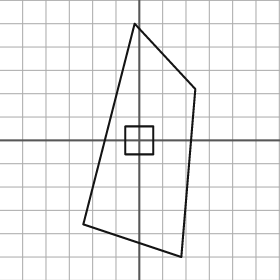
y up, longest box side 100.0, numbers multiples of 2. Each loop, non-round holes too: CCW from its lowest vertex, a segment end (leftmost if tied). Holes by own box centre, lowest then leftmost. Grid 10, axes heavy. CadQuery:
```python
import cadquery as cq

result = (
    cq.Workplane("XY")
    .moveTo(18.0, -50.0)
    .lineTo(24.0, 22.0)
    .lineTo(-2.0, 50.0)
    .lineTo(-24.0, -36.0)
    .close()
    .moveTo(-6.0, -6.0)
    .lineTo(6.0, -6.0)
    .lineTo(6.0, 6.0)
    .lineTo(-6.0, 6.0)
    .close()
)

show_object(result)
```